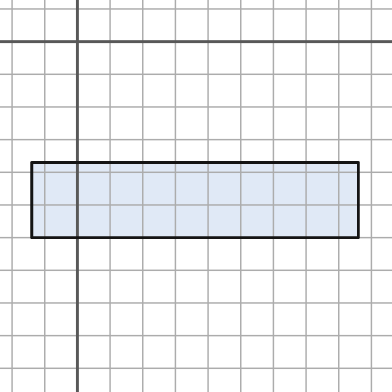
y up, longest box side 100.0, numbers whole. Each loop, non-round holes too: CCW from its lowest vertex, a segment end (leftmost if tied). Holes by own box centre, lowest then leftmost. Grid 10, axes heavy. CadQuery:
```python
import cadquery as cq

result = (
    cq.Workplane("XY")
    .moveTo(-14.0, -60.0)
    .lineTo(86.0, -60.0)
    .lineTo(86.0, -37.0)
    .lineTo(-14.0, -37.0)
    .close()
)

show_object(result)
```